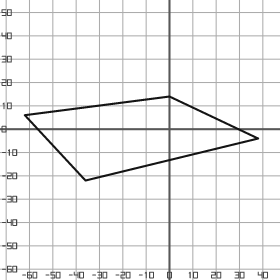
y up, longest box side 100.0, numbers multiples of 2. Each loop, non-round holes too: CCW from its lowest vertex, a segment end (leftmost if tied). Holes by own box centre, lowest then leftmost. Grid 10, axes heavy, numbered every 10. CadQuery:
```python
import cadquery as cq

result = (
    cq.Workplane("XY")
    .moveTo(-36.0, -22.0)
    .lineTo(38.0, -4.0)
    .lineTo(0.0, 14.0)
    .lineTo(-62.0, 6.0)
    .close()
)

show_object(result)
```